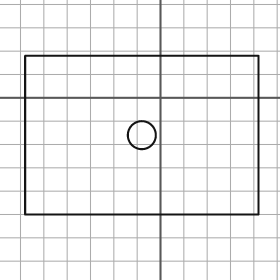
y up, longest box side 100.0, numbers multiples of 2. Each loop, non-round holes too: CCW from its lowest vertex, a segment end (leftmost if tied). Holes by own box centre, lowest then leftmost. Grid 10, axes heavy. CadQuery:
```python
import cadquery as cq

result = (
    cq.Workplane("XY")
    .moveTo(-58.0, -50.0)
    .lineTo(42.0, -50.0)
    .lineTo(42.0, 18.0)
    .lineTo(-58.0, 18.0)
    .close()
    .moveTo(-8.0, -16.0)
    .circle(6.0)
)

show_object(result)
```